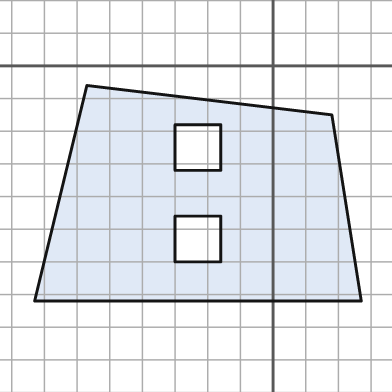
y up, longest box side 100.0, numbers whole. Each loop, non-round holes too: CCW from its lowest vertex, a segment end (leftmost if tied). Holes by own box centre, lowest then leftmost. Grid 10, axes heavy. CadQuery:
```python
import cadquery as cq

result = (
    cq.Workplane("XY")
    .moveTo(-73.0, -72.0)
    .lineTo(27.0, -72.0)
    .lineTo(18.0, -15.0)
    .lineTo(-57.0, -6.0)
    .close()
    .moveTo(-30.0, -60.0)
    .lineTo(-16.0, -60.0)
    .lineTo(-16.0, -46.0)
    .lineTo(-30.0, -46.0)
    .close()
    .moveTo(-30.0, -32.0)
    .lineTo(-16.0, -32.0)
    .lineTo(-16.0, -18.0)
    .lineTo(-30.0, -18.0)
    .close()
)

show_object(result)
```